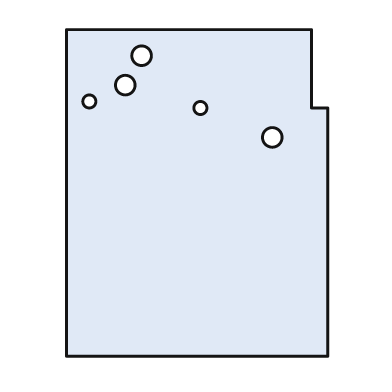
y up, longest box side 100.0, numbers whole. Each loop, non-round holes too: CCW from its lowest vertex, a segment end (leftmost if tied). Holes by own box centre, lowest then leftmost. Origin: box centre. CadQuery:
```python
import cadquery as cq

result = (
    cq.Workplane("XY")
    .moveTo(-40.0, -50.0)
    .lineTo(40.0, -50.0)
    .lineTo(40.0, 26.0)
    .lineTo(35.0, 26.0)
    .lineTo(35.0, 50.0)
    .lineTo(-40.0, 50.0)
    .close()
    .moveTo(23.0, 17.0)
    .circle(3.0)
    .moveTo(1.0, 26.0)
    .circle(2.0)
    .moveTo(-33.0, 28.0)
    .circle(2.0)
    .moveTo(-22.0, 33.0)
    .circle(3.0)
    .moveTo(-17.0, 42.0)
    .circle(3.0)
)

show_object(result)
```